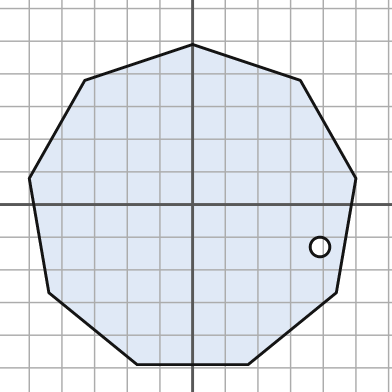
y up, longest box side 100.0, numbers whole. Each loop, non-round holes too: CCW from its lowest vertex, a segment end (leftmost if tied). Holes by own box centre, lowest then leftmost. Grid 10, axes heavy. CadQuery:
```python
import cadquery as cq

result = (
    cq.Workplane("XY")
    .moveTo(-17.0, -49.0)
    .lineTo(17.0, -49.0)
    .lineTo(44.0, -27.0)
    .lineTo(50.0, 8.0)
    .lineTo(33.0, 38.0)
    .lineTo(0.0, 49.0)
    .lineTo(-33.0, 38.0)
    .lineTo(-50.0, 8.0)
    .lineTo(-44.0, -27.0)
    .close()
    .moveTo(39.0, -13.0)
    .circle(3.0)
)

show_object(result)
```